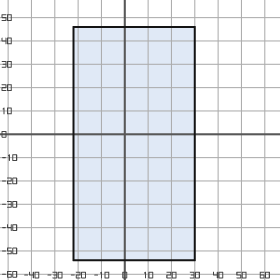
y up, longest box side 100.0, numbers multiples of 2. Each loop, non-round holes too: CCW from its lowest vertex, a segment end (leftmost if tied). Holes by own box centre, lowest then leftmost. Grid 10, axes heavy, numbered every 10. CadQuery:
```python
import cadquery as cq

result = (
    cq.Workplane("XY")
    .moveTo(-22.0, -54.0)
    .lineTo(30.0, -54.0)
    .lineTo(30.0, 46.0)
    .lineTo(-22.0, 46.0)
    .close()
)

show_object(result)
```